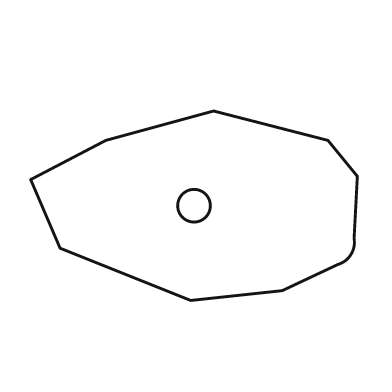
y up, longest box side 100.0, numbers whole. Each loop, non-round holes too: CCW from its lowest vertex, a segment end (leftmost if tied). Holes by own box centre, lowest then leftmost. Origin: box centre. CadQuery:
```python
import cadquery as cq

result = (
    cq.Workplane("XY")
    .moveTo(-1.0, -29.0)
    .lineTo(27.0, -26.0)
    .lineTo(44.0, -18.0)
    .threePointArc((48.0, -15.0), (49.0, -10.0))
    .lineTo(50.0, 9.0)
    .lineTo(41.0, 20.0)
    .lineTo(6.0, 29.0)
    .lineTo(-27.0, 20.0)
    .lineTo(-50.0, 8.0)
    .lineTo(-41.0, -13.0)
    .close()
    .moveTo(0.0, 0.0)
    .circle(5.0)
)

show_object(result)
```